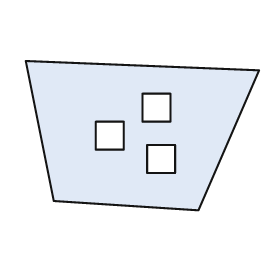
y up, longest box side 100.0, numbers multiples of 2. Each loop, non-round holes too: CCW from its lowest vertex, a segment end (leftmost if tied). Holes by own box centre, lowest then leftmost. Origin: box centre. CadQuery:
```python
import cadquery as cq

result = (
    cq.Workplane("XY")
    .moveTo(24.0, -32.0)
    .lineTo(50.0, 28.0)
    .lineTo(-50.0, 32.0)
    .lineTo(-38.0, -28.0)
    .close()
    .moveTo(2.0, -16.0)
    .lineTo(14.0, -16.0)
    .lineTo(14.0, -4.0)
    .lineTo(2.0, -4.0)
    .close()
    .moveTo(-20.0, -6.0)
    .lineTo(-8.0, -6.0)
    .lineTo(-8.0, 6.0)
    .lineTo(-20.0, 6.0)
    .close()
    .moveTo(0.0, 6.0)
    .lineTo(12.0, 6.0)
    .lineTo(12.0, 18.0)
    .lineTo(0.0, 18.0)
    .close()
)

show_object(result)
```